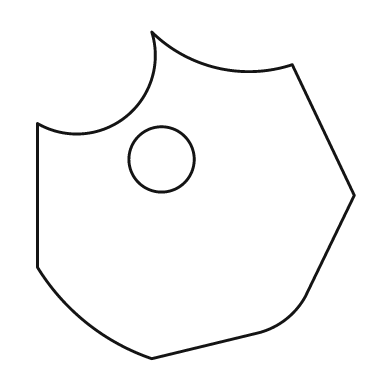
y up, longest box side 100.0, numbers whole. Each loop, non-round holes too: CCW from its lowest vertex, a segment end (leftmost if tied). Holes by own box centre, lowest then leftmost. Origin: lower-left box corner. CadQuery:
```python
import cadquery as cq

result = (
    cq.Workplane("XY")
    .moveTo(35.0, 0.0)
    .lineTo(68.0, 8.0)
    .threePointArc((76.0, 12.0), (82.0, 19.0))
    .lineTo(97.0, 50.0)
    .lineTo(78.0, 90.0)
    .threePointArc((55.0, 89.0), (35.0, 100.0))
    .threePointArc((27.0, 74.0), (0.0, 72.0))
    .lineTo(0.0, 28.0)
    .threePointArc((15.0, 11.0), (35.0, 0.0))
    .close()
    .moveTo(38.0, 61.0)
    .circle(10.0)
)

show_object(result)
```